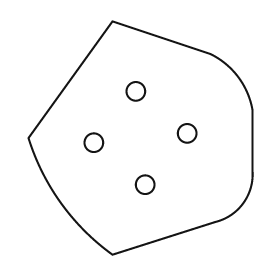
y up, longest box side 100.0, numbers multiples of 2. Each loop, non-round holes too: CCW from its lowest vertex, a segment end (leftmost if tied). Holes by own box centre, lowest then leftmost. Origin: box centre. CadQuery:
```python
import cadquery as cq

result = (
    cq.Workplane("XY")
    .moveTo(-12.0, -50.0)
    .lineTo(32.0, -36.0)
    .threePointArc((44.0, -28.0), (48.0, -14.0))
    .lineTo(48.0, 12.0)
    .threePointArc((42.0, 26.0), (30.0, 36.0))
    .lineTo(-12.0, 50.0)
    .lineTo(-48.0, 0.0)
    .threePointArc((-34.0, -28.0), (-12.0, -50.0))
    .close()
    .moveTo(2.0, -20.0)
    .circle(4.0)
    .moveTo(-20.0, -2.0)
    .circle(4.0)
    .moveTo(20.0, 2.0)
    .circle(4.0)
    .moveTo(-2.0, 20.0)
    .circle(4.0)
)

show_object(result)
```